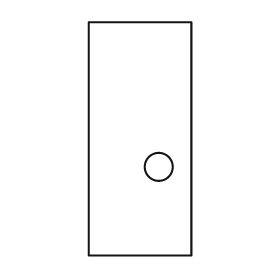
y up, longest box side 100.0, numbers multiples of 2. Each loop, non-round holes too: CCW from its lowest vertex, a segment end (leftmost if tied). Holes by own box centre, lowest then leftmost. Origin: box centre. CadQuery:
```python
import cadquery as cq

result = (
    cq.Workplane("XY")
    .moveTo(-22.0, -50.0)
    .lineTo(22.0, -50.0)
    .lineTo(22.0, 50.0)
    .lineTo(-22.0, 50.0)
    .close()
    .moveTo(8.0, -12.0)
    .circle(6.0)
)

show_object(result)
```